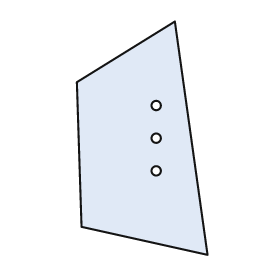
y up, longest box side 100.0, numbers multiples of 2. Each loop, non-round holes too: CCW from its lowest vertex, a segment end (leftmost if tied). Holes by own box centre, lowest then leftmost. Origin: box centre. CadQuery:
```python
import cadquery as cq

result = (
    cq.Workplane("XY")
    .moveTo(28.0, -50.0)
    .lineTo(14.0, 50.0)
    .lineTo(-28.0, 24.0)
    .lineTo(-26.0, -38.0)
    .close()
    .moveTo(6.0, -14.0)
    .circle(2.0)
    .moveTo(6.0, 0.0)
    .circle(2.0)
    .moveTo(6.0, 14.0)
    .circle(2.0)
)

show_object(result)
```